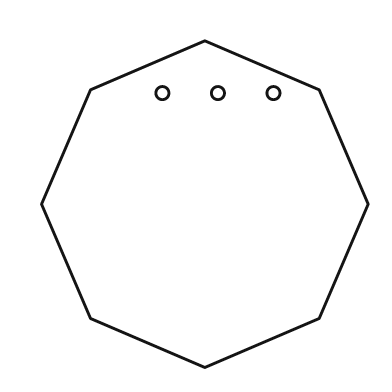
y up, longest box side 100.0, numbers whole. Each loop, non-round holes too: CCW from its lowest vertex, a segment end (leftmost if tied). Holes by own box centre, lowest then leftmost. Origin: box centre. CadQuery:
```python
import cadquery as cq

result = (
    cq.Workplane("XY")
    .moveTo(0.0, -50.0)
    .lineTo(35.0, -35.0)
    .lineTo(50.0, 0.0)
    .lineTo(35.0, 35.0)
    .lineTo(0.0, 50.0)
    .lineTo(-35.0, 35.0)
    .lineTo(-50.0, 0.0)
    .lineTo(-35.0, -35.0)
    .close()
    .moveTo(-13.0, 34.0)
    .circle(2.0)
    .moveTo(4.0, 34.0)
    .circle(2.0)
    .moveTo(21.0, 34.0)
    .circle(2.0)
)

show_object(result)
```